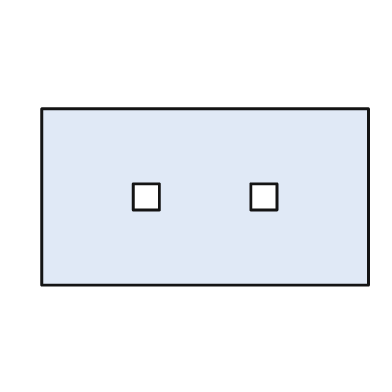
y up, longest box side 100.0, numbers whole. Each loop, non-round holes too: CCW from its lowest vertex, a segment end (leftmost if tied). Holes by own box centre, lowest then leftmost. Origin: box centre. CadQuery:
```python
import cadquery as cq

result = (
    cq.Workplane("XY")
    .moveTo(-50.0, -27.0)
    .lineTo(50.0, -27.0)
    .lineTo(50.0, 27.0)
    .lineTo(-50.0, 27.0)
    .close()
    .moveTo(-22.0, -4.0)
    .lineTo(-14.0, -4.0)
    .lineTo(-14.0, 4.0)
    .lineTo(-22.0, 4.0)
    .close()
    .moveTo(14.0, -4.0)
    .lineTo(22.0, -4.0)
    .lineTo(22.0, 4.0)
    .lineTo(14.0, 4.0)
    .close()
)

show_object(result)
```